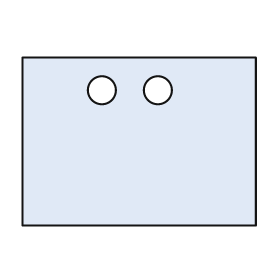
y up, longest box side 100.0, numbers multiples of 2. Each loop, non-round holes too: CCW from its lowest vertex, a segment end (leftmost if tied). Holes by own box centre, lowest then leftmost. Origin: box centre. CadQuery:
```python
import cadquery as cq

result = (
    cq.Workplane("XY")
    .moveTo(-50.0, -36.0)
    .lineTo(50.0, -36.0)
    .lineTo(50.0, 36.0)
    .lineTo(-50.0, 36.0)
    .close()
    .moveTo(-16.0, 22.0)
    .circle(6.0)
    .moveTo(8.0, 22.0)
    .circle(6.0)
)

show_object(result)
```